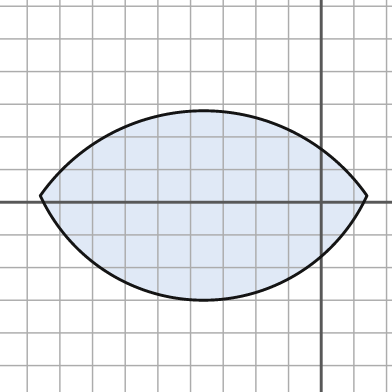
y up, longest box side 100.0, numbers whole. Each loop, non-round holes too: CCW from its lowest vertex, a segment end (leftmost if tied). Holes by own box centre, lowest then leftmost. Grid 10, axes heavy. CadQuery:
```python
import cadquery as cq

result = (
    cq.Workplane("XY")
    .moveTo(-86.0, 2.0)
    .threePointArc((-36.0, -30.0), (14.0, 2.0))
    .threePointArc((-36.0, 28.0), (-86.0, 2.0))
    .close()
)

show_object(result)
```